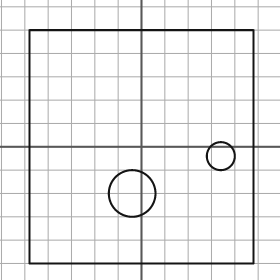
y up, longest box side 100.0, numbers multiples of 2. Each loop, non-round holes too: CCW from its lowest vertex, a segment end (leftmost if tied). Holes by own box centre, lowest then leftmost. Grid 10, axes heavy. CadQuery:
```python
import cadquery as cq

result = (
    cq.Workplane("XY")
    .moveTo(-48.0, -50.0)
    .lineTo(48.0, -50.0)
    .lineTo(48.0, 50.0)
    .lineTo(-48.0, 50.0)
    .close()
    .moveTo(-4.0, -20.0)
    .circle(10.0)
    .moveTo(34.0, -4.0)
    .circle(6.0)
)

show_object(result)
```